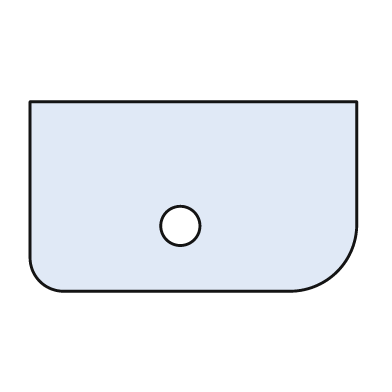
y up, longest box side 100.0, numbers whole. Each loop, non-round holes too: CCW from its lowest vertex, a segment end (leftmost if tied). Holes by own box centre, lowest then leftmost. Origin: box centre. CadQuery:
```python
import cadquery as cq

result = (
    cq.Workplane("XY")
    .moveTo(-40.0, -29.0)
    .lineTo(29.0, -29.0)
    .threePointArc((44.0, -23.0), (50.0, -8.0))
    .lineTo(50.0, 29.0)
    .lineTo(-50.0, 29.0)
    .lineTo(-50.0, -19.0)
    .threePointArc((-47.0, -26.0), (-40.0, -29.0))
    .close()
    .moveTo(-4.0, -9.0)
    .circle(6.0)
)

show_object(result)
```